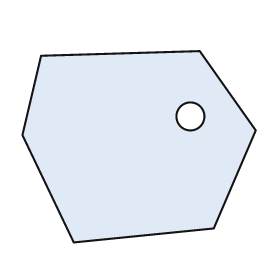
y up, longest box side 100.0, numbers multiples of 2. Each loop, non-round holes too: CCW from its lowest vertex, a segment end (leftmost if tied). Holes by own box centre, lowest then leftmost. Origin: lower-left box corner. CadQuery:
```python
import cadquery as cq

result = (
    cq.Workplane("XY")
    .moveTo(22.0, 0.0)
    .lineTo(82.0, 6.0)
    .lineTo(100.0, 48.0)
    .lineTo(76.0, 82.0)
    .lineTo(8.0, 80.0)
    .lineTo(0.0, 46.0)
    .close()
    .moveTo(72.0, 54.0)
    .circle(6.0)
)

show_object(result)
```